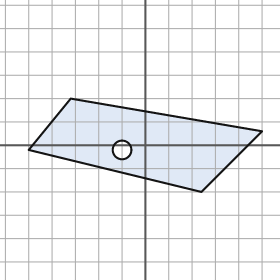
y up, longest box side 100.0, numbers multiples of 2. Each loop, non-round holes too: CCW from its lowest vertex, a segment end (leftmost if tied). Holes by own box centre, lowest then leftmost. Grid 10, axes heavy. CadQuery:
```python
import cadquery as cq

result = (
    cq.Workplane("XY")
    .moveTo(24.0, -20.0)
    .lineTo(50.0, 6.0)
    .lineTo(-32.0, 20.0)
    .lineTo(-50.0, -2.0)
    .close()
    .moveTo(-10.0, -2.0)
    .circle(4.0)
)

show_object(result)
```